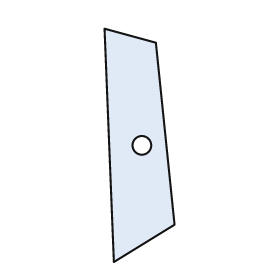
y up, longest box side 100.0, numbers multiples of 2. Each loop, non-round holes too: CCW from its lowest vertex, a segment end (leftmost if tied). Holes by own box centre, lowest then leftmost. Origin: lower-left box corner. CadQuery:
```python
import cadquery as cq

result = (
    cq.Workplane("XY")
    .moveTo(4.0, 0.0)
    .lineTo(30.0, 16.0)
    .lineTo(22.0, 94.0)
    .lineTo(0.0, 100.0)
    .close()
    .moveTo(16.0, 50.0)
    .circle(4.0)
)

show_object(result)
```